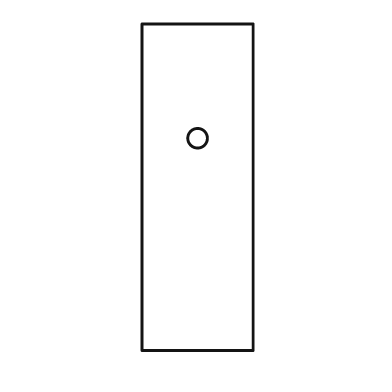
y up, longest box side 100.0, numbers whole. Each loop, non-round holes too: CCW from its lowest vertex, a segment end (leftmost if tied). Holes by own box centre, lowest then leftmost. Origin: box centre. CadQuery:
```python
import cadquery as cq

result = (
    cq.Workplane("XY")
    .moveTo(-17.0, -50.0)
    .lineTo(17.0, -50.0)
    .lineTo(17.0, 50.0)
    .lineTo(-17.0, 50.0)
    .close()
    .moveTo(0.0, 15.0)
    .circle(3.0)
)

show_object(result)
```